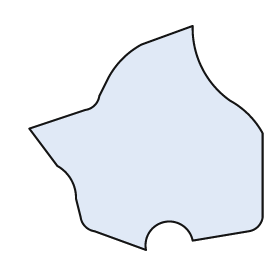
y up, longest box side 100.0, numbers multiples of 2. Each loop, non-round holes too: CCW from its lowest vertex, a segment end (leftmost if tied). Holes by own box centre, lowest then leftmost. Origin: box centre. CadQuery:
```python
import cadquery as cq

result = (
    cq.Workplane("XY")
    .moveTo(0.0, -48.0)
    .threePointArc((8.0, -36.0), (20.0, -44.0))
    .lineTo(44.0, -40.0)
    .threePointArc((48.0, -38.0), (50.0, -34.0))
    .lineTo(50.0, 2.0)
    .threePointArc((44.0, 10.0), (36.0, 16.0))
    .threePointArc((24.0, 30.0), (20.0, 48.0))
    .lineTo(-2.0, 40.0)
    .threePointArc((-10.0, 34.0), (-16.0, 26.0))
    .lineTo(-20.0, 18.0)
    .threePointArc((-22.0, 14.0), (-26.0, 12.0))
    .lineTo(-50.0, 4.0)
    .lineTo(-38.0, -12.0)
    .threePointArc((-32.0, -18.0), (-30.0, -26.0))
    .lineTo(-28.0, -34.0)
    .threePointArc((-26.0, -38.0), (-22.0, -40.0))
    .close()
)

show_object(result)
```